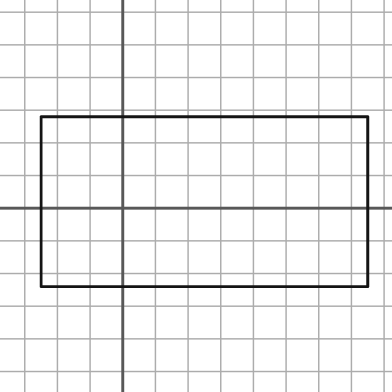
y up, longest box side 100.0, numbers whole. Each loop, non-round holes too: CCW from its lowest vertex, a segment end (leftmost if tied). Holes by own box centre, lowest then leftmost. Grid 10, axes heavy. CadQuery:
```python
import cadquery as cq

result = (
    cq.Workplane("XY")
    .moveTo(-25.0, -24.0)
    .lineTo(75.0, -24.0)
    .lineTo(75.0, 28.0)
    .lineTo(-25.0, 28.0)
    .close()
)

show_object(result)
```